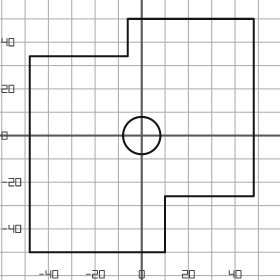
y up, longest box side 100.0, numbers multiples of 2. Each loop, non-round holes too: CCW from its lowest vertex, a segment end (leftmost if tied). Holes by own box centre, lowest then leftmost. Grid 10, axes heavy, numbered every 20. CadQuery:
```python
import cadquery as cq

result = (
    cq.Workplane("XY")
    .moveTo(-48.0, -50.0)
    .lineTo(10.0, -50.0)
    .lineTo(10.0, -26.0)
    .lineTo(48.0, -26.0)
    .lineTo(48.0, 50.0)
    .lineTo(-6.0, 50.0)
    .lineTo(-6.0, 34.0)
    .lineTo(-48.0, 34.0)
    .close()
    .moveTo(0.0, 0.0)
    .circle(8.0)
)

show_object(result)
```